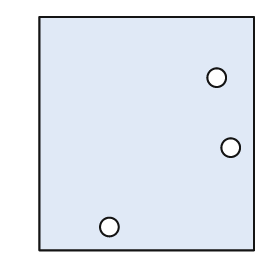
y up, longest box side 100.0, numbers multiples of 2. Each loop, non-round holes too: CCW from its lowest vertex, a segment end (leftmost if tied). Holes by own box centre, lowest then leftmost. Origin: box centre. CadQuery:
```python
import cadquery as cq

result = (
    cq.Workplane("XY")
    .moveTo(-46.0, -50.0)
    .lineTo(46.0, -50.0)
    .lineTo(46.0, 50.0)
    .lineTo(-46.0, 50.0)
    .close()
    .moveTo(-16.0, -40.0)
    .circle(4.0)
    .moveTo(36.0, -6.0)
    .circle(4.0)
    .moveTo(30.0, 24.0)
    .circle(4.0)
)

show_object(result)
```